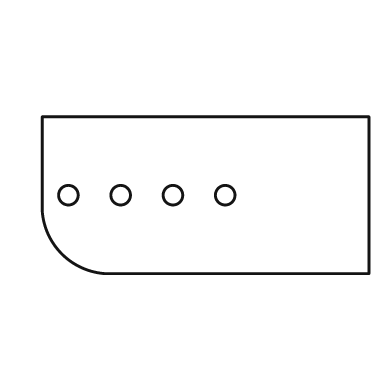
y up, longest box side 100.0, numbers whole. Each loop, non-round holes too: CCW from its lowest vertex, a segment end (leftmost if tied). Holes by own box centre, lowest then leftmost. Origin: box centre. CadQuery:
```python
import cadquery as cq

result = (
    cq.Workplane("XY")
    .moveTo(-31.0, -24.0)
    .lineTo(50.0, -24.0)
    .lineTo(50.0, 24.0)
    .lineTo(-50.0, 24.0)
    .lineTo(-50.0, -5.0)
    .threePointArc((-44.0, -18.0), (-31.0, -24.0))
    .close()
    .moveTo(-42.0, 0.0)
    .circle(3.0)
    .moveTo(-26.0, 0.0)
    .circle(3.0)
    .moveTo(-10.0, 0.0)
    .circle(3.0)
    .moveTo(6.0, 0.0)
    .circle(3.0)
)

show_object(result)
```